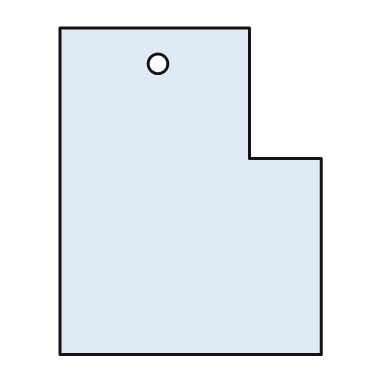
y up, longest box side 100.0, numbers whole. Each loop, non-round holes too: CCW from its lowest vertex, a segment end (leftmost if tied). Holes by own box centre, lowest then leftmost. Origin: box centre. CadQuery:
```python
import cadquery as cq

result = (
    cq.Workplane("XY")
    .moveTo(-40.0, -50.0)
    .lineTo(40.0, -50.0)
    .lineTo(40.0, 10.0)
    .lineTo(18.0, 10.0)
    .lineTo(18.0, 50.0)
    .lineTo(-40.0, 50.0)
    .close()
    .moveTo(-10.0, 39.0)
    .circle(3.0)
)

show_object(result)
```